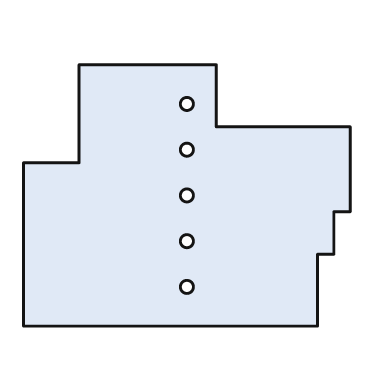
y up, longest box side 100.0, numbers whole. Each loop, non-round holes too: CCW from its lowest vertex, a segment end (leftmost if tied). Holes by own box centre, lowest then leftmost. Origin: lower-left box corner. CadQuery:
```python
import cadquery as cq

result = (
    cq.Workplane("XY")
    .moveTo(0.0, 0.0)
    .lineTo(90.0, 0.0)
    .lineTo(90.0, 22.0)
    .lineTo(95.0, 22.0)
    .lineTo(95.0, 35.0)
    .lineTo(100.0, 35.0)
    .lineTo(100.0, 61.0)
    .lineTo(59.0, 61.0)
    .lineTo(59.0, 80.0)
    .lineTo(17.0, 80.0)
    .lineTo(17.0, 50.0)
    .lineTo(0.0, 50.0)
    .close()
    .moveTo(50.0, 12.0)
    .circle(2.0)
    .moveTo(50.0, 26.0)
    .circle(2.0)
    .moveTo(50.0, 40.0)
    .circle(2.0)
    .moveTo(50.0, 54.0)
    .circle(2.0)
    .moveTo(50.0, 68.0)
    .circle(2.0)
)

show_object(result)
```